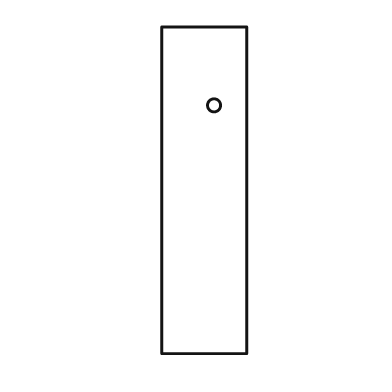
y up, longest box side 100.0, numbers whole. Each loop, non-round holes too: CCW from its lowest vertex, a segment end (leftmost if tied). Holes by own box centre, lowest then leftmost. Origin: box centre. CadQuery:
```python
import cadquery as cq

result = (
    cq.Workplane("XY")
    .moveTo(-13.0, -50.0)
    .lineTo(13.0, -50.0)
    .lineTo(13.0, 50.0)
    .lineTo(-13.0, 50.0)
    .close()
    .moveTo(3.0, 26.0)
    .circle(2.0)
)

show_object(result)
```